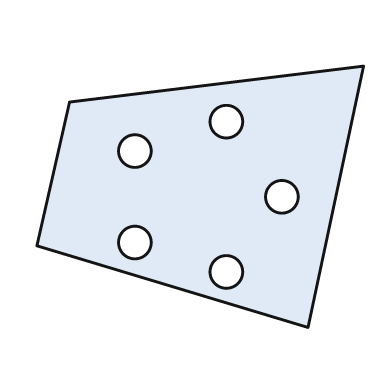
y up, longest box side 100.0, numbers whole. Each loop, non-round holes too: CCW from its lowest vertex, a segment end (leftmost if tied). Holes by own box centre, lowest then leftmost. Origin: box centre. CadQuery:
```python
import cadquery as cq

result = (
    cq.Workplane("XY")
    .moveTo(33.0, -40.0)
    .lineTo(50.0, 40.0)
    .lineTo(-40.0, 29.0)
    .lineTo(-50.0, -15.0)
    .close()
    .moveTo(8.0, -23.0)
    .circle(5.0)
    .moveTo(-20.0, -14.0)
    .circle(5.0)
    .moveTo(25.0, 0.0)
    .circle(5.0)
    .moveTo(-20.0, 14.0)
    .circle(5.0)
    .moveTo(8.0, 23.0)
    .circle(5.0)
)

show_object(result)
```